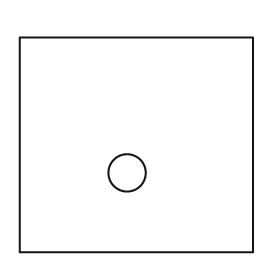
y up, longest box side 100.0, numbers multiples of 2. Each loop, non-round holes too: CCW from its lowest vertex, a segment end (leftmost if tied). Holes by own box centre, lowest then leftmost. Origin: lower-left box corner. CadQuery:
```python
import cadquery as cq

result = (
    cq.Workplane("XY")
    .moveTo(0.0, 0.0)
    .lineTo(100.0, 0.0)
    .lineTo(100.0, 92.0)
    .lineTo(0.0, 92.0)
    .close()
    .moveTo(46.0, 34.0)
    .circle(8.0)
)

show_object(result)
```